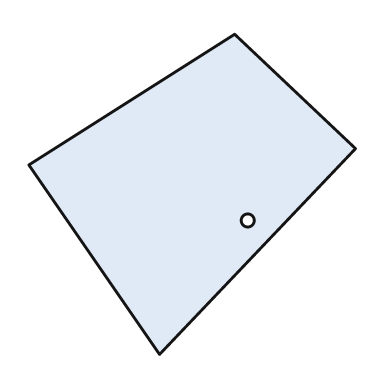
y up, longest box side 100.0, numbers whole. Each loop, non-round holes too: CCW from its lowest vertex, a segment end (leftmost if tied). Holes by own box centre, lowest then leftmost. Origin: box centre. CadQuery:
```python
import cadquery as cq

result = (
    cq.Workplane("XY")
    .moveTo(-10.0, -49.0)
    .lineTo(50.0, 14.0)
    .lineTo(13.0, 49.0)
    .lineTo(-50.0, 9.0)
    .close()
    .moveTo(17.0, -8.0)
    .circle(2.0)
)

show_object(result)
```